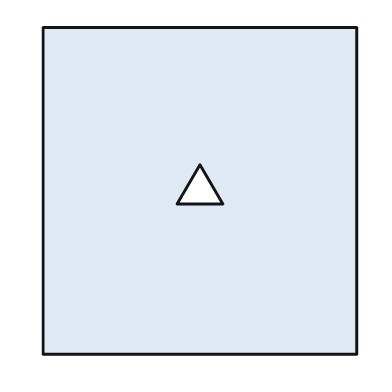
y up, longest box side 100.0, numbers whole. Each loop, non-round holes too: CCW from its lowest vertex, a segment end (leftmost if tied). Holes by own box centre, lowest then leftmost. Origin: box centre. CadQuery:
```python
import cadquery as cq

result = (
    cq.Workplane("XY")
    .moveTo(-48.0, -50.0)
    .lineTo(48.0, -50.0)
    .lineTo(48.0, 50.0)
    .lineTo(-48.0, 50.0)
    .close()
    .moveTo(-7.0, -4.0)
    .lineTo(7.0, -4.0)
    .lineTo(0.0, 8.0)
    .close()
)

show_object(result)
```